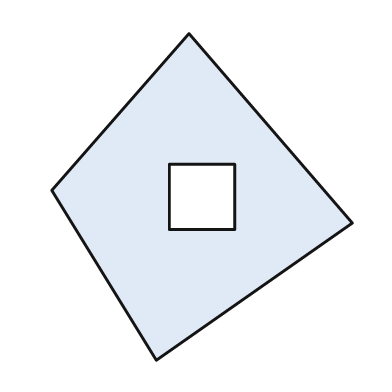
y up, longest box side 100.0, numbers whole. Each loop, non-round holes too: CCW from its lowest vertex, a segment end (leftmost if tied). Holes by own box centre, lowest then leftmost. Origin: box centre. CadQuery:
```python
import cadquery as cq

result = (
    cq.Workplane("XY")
    .moveTo(-14.0, -50.0)
    .lineTo(46.0, -8.0)
    .lineTo(-4.0, 50.0)
    .lineTo(-46.0, 2.0)
    .close()
    .moveTo(-10.0, -10.0)
    .lineTo(10.0, -10.0)
    .lineTo(10.0, 10.0)
    .lineTo(-10.0, 10.0)
    .close()
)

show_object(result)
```